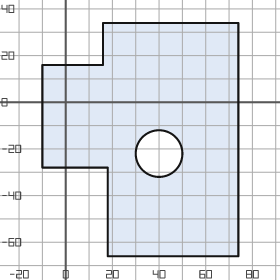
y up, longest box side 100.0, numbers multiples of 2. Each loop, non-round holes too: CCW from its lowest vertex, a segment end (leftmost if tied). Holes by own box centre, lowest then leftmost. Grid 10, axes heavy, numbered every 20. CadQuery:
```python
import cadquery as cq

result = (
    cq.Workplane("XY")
    .moveTo(18.0, -66.0)
    .lineTo(74.0, -66.0)
    .lineTo(74.0, 34.0)
    .lineTo(16.0, 34.0)
    .lineTo(16.0, 16.0)
    .lineTo(-10.0, 16.0)
    .lineTo(-10.0, -28.0)
    .lineTo(18.0, -28.0)
    .close()
    .moveTo(40.0, -22.0)
    .circle(10.0)
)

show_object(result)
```